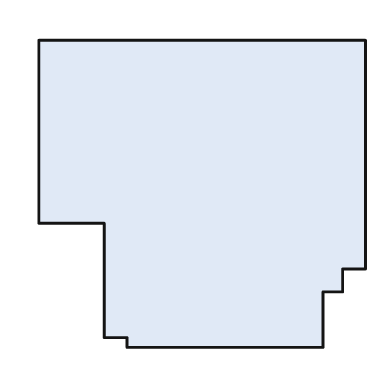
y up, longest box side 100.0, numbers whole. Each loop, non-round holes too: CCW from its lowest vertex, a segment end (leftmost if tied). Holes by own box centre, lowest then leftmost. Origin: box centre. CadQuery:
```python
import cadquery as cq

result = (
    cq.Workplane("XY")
    .moveTo(-23.0, -47.0)
    .lineTo(37.0, -47.0)
    .lineTo(37.0, -30.0)
    .lineTo(43.0, -30.0)
    .lineTo(43.0, -23.0)
    .lineTo(50.0, -23.0)
    .lineTo(50.0, 47.0)
    .lineTo(-50.0, 47.0)
    .lineTo(-50.0, -9.0)
    .lineTo(-30.0, -9.0)
    .lineTo(-30.0, -44.0)
    .lineTo(-23.0, -44.0)
    .close()
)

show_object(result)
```